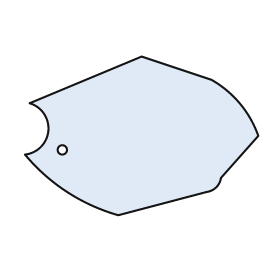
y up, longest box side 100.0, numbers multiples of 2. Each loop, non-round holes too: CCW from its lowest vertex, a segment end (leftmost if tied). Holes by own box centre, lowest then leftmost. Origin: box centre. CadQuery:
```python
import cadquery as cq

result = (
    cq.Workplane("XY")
    .moveTo(-10.0, -34.0)
    .lineTo(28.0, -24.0)
    .threePointArc((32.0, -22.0), (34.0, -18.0))
    .lineTo(50.0, 0.0)
    .threePointArc((42.0, 14.0), (30.0, 24.0))
    .lineTo(0.0, 34.0)
    .lineTo(-48.0, 14.0)
    .threePointArc((-40.0, 2.0), (-50.0, -8.0))
    .threePointArc((-32.0, -24.0), (-10.0, -34.0))
    .close()
    .moveTo(-34.0, -6.0)
    .circle(2.0)
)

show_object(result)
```